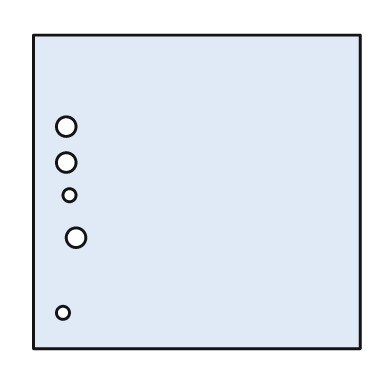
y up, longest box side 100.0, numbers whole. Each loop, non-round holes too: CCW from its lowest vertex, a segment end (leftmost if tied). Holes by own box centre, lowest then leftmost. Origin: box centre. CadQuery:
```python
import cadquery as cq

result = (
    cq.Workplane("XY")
    .moveTo(-50.0, -48.0)
    .lineTo(50.0, -48.0)
    .lineTo(50.0, 48.0)
    .lineTo(-50.0, 48.0)
    .close()
    .moveTo(-41.0, -37.0)
    .circle(2.0)
    .moveTo(-37.0, -14.0)
    .circle(3.0)
    .moveTo(-39.0, -1.0)
    .circle(2.0)
    .moveTo(-40.0, 9.0)
    .circle(3.0)
    .moveTo(-40.0, 20.0)
    .circle(3.0)
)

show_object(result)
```